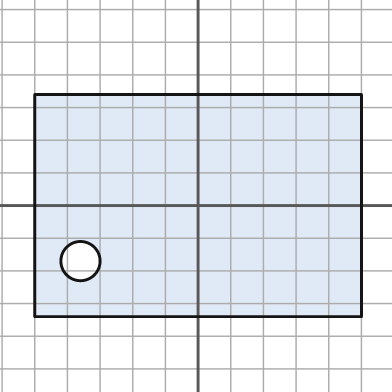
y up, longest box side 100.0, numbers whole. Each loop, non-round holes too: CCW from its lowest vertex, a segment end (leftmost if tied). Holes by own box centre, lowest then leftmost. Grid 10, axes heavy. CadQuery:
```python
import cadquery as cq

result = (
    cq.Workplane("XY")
    .moveTo(-50.0, -34.0)
    .lineTo(50.0, -34.0)
    .lineTo(50.0, 34.0)
    .lineTo(-50.0, 34.0)
    .close()
    .moveTo(-36.0, -17.0)
    .circle(6.0)
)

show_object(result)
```